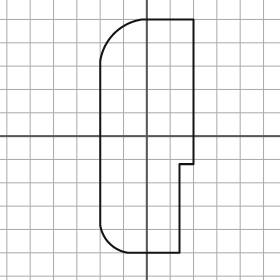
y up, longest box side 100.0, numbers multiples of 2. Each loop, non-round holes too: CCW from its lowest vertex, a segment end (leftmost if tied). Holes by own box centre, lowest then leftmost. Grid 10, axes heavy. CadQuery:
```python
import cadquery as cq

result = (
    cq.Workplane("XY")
    .moveTo(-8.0, -50.0)
    .lineTo(14.0, -50.0)
    .lineTo(14.0, -12.0)
    .lineTo(20.0, -12.0)
    .lineTo(20.0, 50.0)
    .lineTo(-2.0, 50.0)
    .threePointArc((-14.0, 44.0), (-20.0, 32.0))
    .lineTo(-20.0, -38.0)
    .threePointArc((-16.0, -46.0), (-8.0, -50.0))
    .close()
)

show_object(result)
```